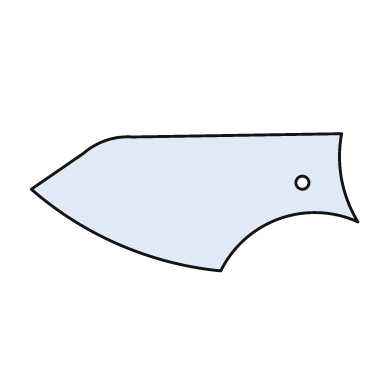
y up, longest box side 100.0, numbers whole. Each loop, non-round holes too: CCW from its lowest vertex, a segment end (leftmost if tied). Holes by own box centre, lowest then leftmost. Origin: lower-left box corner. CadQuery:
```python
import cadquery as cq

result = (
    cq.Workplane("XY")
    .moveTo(58.0, 0.0)
    .threePointArc((76.0, 16.0), (100.0, 15.0))
    .threePointArc((95.0, 28.0), (95.0, 42.0))
    .lineTo(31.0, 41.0)
    .threePointArc((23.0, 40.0), (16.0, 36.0))
    .lineTo(0.0, 25.0)
    .threePointArc((27.0, 8.0), (58.0, 0.0))
    .close()
    .moveTo(83.0, 27.0)
    .circle(2.0)
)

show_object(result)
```